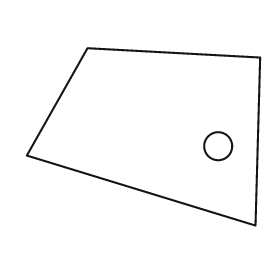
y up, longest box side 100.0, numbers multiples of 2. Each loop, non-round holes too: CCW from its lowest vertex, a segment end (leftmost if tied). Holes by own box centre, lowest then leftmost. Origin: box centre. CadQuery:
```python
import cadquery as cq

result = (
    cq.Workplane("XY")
    .moveTo(48.0, -38.0)
    .lineTo(50.0, 34.0)
    .lineTo(-24.0, 38.0)
    .lineTo(-50.0, -8.0)
    .close()
    .moveTo(32.0, -4.0)
    .circle(6.0)
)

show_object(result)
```